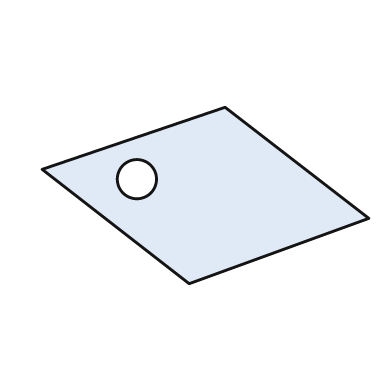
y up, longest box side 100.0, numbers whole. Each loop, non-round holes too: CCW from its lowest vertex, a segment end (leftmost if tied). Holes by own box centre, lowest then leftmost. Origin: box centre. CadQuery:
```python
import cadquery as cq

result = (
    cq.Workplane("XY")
    .moveTo(-5.0, -27.0)
    .lineTo(50.0, -7.0)
    .lineTo(6.0, 27.0)
    .lineTo(-50.0, 8.0)
    .close()
    .moveTo(-21.0, 5.0)
    .circle(6.0)
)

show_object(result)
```